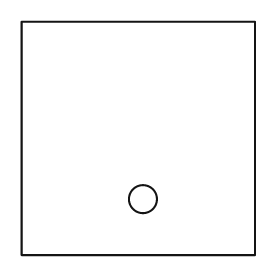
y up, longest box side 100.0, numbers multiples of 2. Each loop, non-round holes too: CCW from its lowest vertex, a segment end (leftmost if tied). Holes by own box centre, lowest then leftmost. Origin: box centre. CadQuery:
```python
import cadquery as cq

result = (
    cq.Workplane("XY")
    .moveTo(-50.0, -50.0)
    .lineTo(50.0, -50.0)
    .lineTo(50.0, 50.0)
    .lineTo(-50.0, 50.0)
    .close()
    .moveTo(2.0, -26.0)
    .circle(6.0)
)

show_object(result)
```